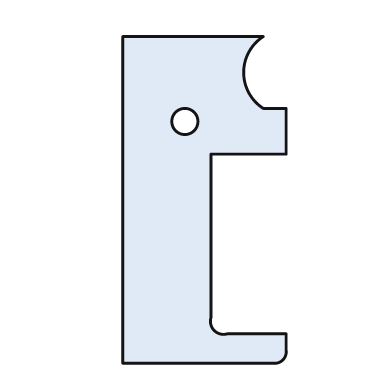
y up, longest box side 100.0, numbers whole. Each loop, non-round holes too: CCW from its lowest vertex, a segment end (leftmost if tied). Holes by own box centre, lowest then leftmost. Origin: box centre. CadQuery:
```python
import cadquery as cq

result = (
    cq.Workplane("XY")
    .moveTo(-25.0, -50.0)
    .lineTo(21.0, -50.0)
    .threePointArc((24.0, -49.0), (25.0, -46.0))
    .lineTo(25.0, -41.0)
    .lineTo(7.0, -41.0)
    .threePointArc((3.0, -40.0), (2.0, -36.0))
    .lineTo(2.0, 14.0)
    .lineTo(25.0, 14.0)
    .lineTo(25.0, 28.0)
    .lineTo(18.0, 28.0)
    .threePointArc((12.0, 39.0), (18.0, 50.0))
    .lineTo(-25.0, 50.0)
    .close()
    .moveTo(-6.0, 24.0)
    .circle(4.0)
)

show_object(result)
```